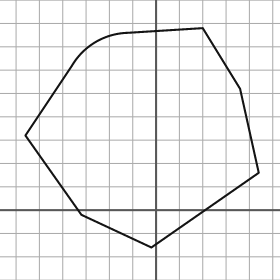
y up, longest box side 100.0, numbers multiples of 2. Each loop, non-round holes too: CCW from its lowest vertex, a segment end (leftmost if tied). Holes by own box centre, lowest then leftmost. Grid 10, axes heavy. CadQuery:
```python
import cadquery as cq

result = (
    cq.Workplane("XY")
    .moveTo(-2.0, -16.0)
    .lineTo(44.0, 16.0)
    .lineTo(36.0, 52.0)
    .lineTo(20.0, 78.0)
    .lineTo(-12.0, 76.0)
    .threePointArc((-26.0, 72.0), (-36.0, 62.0))
    .lineTo(-56.0, 32.0)
    .lineTo(-32.0, -2.0)
    .close()
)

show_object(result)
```